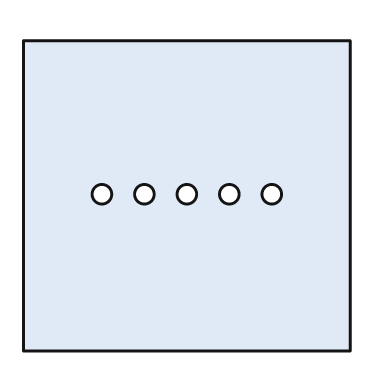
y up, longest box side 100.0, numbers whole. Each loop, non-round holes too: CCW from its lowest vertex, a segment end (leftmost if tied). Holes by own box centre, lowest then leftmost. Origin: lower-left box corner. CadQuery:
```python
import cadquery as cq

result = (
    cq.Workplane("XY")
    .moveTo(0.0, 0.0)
    .lineTo(100.0, 0.0)
    .lineTo(100.0, 95.0)
    .lineTo(0.0, 95.0)
    .close()
    .moveTo(24.0, 48.0)
    .circle(3.0)
    .moveTo(37.0, 48.0)
    .circle(3.0)
    .moveTo(50.0, 48.0)
    .circle(3.0)
    .moveTo(63.0, 48.0)
    .circle(3.0)
    .moveTo(76.0, 48.0)
    .circle(3.0)
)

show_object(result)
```